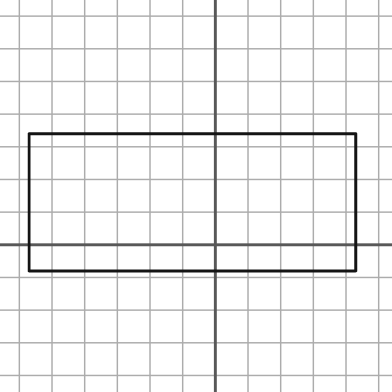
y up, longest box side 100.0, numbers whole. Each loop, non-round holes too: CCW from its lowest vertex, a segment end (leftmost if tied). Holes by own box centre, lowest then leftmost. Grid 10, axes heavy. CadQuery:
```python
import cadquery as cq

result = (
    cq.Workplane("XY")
    .moveTo(-57.0, -8.0)
    .lineTo(43.0, -8.0)
    .lineTo(43.0, 34.0)
    .lineTo(-57.0, 34.0)
    .close()
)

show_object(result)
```